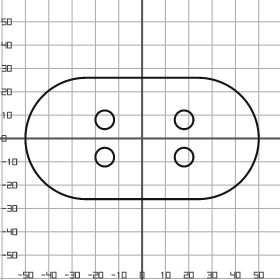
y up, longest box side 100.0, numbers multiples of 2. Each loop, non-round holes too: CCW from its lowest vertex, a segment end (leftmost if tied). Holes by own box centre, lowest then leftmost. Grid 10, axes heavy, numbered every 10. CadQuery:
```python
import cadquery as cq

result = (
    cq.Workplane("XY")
    .moveTo(-24.0, -26.0)
    .lineTo(24.0, -26.0)
    .threePointArc((50.0, 0.0), (24.0, 26.0))
    .lineTo(-24.0, 26.0)
    .threePointArc((-50.0, 0.0), (-24.0, -26.0))
    .close()
    .moveTo(-16.0, -8.0)
    .circle(4.0)
    .moveTo(18.0, -8.0)
    .circle(4.0)
    .moveTo(-16.0, 8.0)
    .circle(4.0)
    .moveTo(18.0, 8.0)
    .circle(4.0)
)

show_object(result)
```